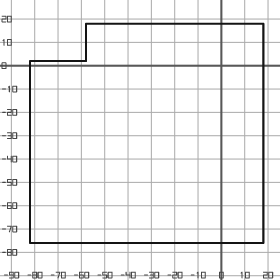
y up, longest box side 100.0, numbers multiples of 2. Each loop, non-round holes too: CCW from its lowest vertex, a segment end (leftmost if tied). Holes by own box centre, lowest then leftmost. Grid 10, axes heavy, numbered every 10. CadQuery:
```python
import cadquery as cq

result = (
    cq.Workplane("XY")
    .moveTo(-82.0, -76.0)
    .lineTo(18.0, -76.0)
    .lineTo(18.0, 18.0)
    .lineTo(-58.0, 18.0)
    .lineTo(-58.0, 2.0)
    .lineTo(-82.0, 2.0)
    .close()
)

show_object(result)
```